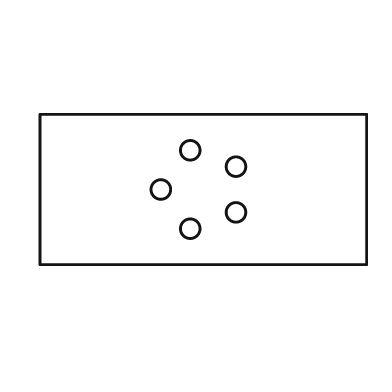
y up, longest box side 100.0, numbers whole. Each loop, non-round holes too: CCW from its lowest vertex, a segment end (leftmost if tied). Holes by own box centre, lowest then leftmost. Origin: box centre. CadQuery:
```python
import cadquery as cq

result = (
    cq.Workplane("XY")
    .moveTo(-50.0, -23.0)
    .lineTo(50.0, -23.0)
    .lineTo(50.0, 23.0)
    .lineTo(-50.0, 23.0)
    .close()
    .moveTo(-4.0, -12.0)
    .circle(3.0)
    .moveTo(10.0, -7.0)
    .circle(3.0)
    .moveTo(-13.0, 0.0)
    .circle(3.0)
    .moveTo(10.0, 7.0)
    .circle(3.0)
    .moveTo(-4.0, 12.0)
    .circle(3.0)
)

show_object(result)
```